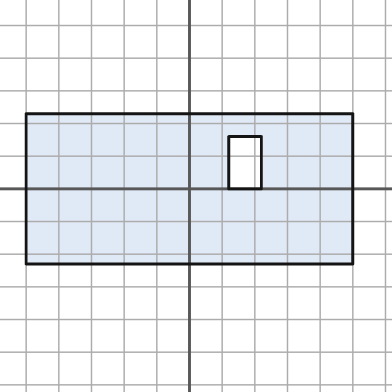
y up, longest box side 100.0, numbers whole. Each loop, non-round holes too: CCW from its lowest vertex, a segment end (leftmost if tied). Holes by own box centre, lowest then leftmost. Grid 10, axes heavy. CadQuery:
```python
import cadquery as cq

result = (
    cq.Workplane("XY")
    .moveTo(-50.0, -23.0)
    .lineTo(50.0, -23.0)
    .lineTo(50.0, 23.0)
    .lineTo(-50.0, 23.0)
    .close()
    .moveTo(12.0, 0.0)
    .lineTo(22.0, 0.0)
    .lineTo(22.0, 16.0)
    .lineTo(12.0, 16.0)
    .close()
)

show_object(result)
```